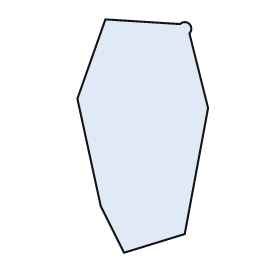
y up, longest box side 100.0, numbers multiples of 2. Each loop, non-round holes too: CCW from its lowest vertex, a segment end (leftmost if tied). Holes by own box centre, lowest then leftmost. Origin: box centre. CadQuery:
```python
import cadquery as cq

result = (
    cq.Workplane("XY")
    .moveTo(-8.0, -50.0)
    .lineTo(18.0, -42.0)
    .lineTo(28.0, 12.0)
    .lineTo(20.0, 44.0)
    .threePointArc((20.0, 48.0), (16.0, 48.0))
    .lineTo(-16.0, 50.0)
    .lineTo(-28.0, 16.0)
    .lineTo(-18.0, -30.0)
    .close()
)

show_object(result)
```